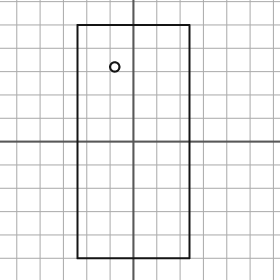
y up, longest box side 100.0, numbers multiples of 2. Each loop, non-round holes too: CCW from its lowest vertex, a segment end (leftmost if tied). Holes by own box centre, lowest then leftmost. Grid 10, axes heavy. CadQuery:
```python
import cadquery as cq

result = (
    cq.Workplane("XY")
    .moveTo(-24.0, -50.0)
    .lineTo(24.0, -50.0)
    .lineTo(24.0, 50.0)
    .lineTo(-24.0, 50.0)
    .close()
    .moveTo(-8.0, 32.0)
    .circle(2.0)
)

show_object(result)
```